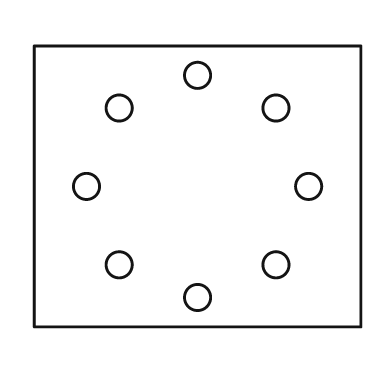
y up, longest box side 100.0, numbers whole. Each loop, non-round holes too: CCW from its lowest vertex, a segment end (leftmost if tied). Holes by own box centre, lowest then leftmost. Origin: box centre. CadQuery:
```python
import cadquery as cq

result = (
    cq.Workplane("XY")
    .moveTo(-50.0, -43.0)
    .lineTo(50.0, -43.0)
    .lineTo(50.0, 43.0)
    .lineTo(-50.0, 43.0)
    .close()
    .moveTo(0.0, -34.0)
    .circle(4.0)
    .moveTo(-24.0, -24.0)
    .circle(4.0)
    .moveTo(24.0, -24.0)
    .circle(4.0)
    .moveTo(-34.0, 0.0)
    .circle(4.0)
    .moveTo(34.0, 0.0)
    .circle(4.0)
    .moveTo(-24.0, 24.0)
    .circle(4.0)
    .moveTo(24.0, 24.0)
    .circle(4.0)
    .moveTo(0.0, 34.0)
    .circle(4.0)
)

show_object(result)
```